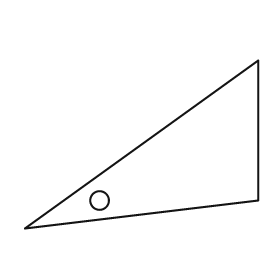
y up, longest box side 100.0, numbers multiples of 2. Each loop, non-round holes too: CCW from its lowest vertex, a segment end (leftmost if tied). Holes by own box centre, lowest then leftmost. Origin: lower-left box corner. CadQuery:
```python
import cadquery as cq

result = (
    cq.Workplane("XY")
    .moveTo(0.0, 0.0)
    .lineTo(100.0, 12.0)
    .lineTo(100.0, 72.0)
    .close()
    .moveTo(32.0, 12.0)
    .circle(4.0)
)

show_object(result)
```